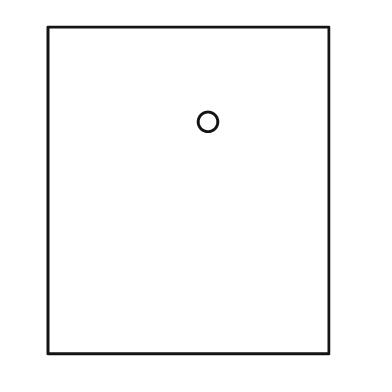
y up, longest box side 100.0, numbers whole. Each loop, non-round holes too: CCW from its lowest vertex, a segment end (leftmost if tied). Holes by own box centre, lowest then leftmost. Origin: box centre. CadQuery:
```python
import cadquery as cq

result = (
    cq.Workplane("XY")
    .moveTo(-43.0, -50.0)
    .lineTo(43.0, -50.0)
    .lineTo(43.0, 50.0)
    .lineTo(-43.0, 50.0)
    .close()
    .moveTo(6.0, 21.0)
    .circle(3.0)
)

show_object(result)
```